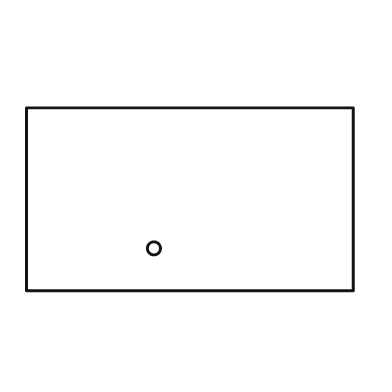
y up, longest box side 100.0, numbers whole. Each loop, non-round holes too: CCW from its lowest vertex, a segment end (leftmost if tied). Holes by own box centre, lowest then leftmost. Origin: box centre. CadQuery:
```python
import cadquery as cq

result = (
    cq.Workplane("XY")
    .moveTo(-50.0, -28.0)
    .lineTo(50.0, -28.0)
    .lineTo(50.0, 28.0)
    .lineTo(-50.0, 28.0)
    .close()
    .moveTo(-11.0, -15.0)
    .circle(2.0)
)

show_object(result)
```